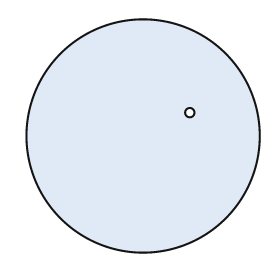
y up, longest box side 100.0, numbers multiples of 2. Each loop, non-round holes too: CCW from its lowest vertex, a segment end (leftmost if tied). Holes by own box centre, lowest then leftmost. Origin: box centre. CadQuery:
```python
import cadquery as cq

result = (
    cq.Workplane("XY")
    .moveTo(0.0, 0.0)
    .circle(50.0)
    .moveTo(20.0, 10.0)
    .circle(2.0)
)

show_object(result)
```